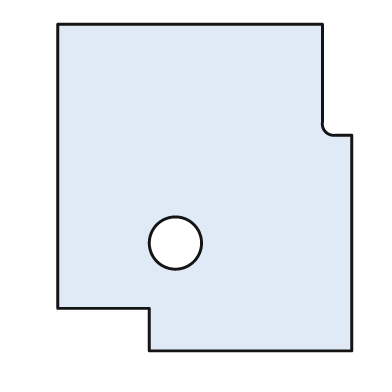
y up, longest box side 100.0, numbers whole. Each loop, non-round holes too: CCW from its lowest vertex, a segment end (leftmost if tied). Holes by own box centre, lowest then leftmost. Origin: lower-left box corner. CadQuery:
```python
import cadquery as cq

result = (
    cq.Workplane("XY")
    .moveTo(28.0, 0.0)
    .lineTo(90.0, 0.0)
    .lineTo(90.0, 66.0)
    .lineTo(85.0, 66.0)
    .threePointArc((82.0, 67.0), (81.0, 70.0))
    .lineTo(81.0, 100.0)
    .lineTo(0.0, 100.0)
    .lineTo(0.0, 13.0)
    .lineTo(28.0, 13.0)
    .close()
    .moveTo(36.0, 33.0)
    .circle(8.0)
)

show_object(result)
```